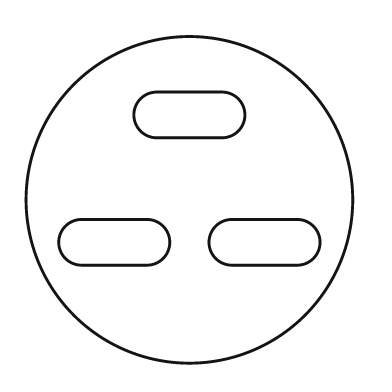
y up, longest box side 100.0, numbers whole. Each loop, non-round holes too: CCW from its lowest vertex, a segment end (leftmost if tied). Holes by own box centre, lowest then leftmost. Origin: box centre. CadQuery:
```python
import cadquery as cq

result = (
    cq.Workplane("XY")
    .moveTo(0.0, 0.0)
    .circle(50.0)
    .moveTo(-33.0, -20.0)
    .lineTo(-13.0, -20.0)
    .threePointArc((-6.0, -13.0), (-13.0, -6.0))
    .lineTo(-33.0, -6.0)
    .threePointArc((-40.0, -13.0), (-33.0, -20.0))
    .close()
    .moveTo(13.0, -20.0)
    .lineTo(33.0, -20.0)
    .threePointArc((40.0, -13.0), (33.0, -6.0))
    .lineTo(13.0, -6.0)
    .threePointArc((6.0, -13.0), (13.0, -20.0))
    .close()
    .moveTo(-10.0, 19.0)
    .lineTo(10.0, 19.0)
    .threePointArc((17.0, 26.0), (10.0, 33.0))
    .lineTo(-10.0, 33.0)
    .threePointArc((-17.0, 26.0), (-10.0, 19.0))
    .close()
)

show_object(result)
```